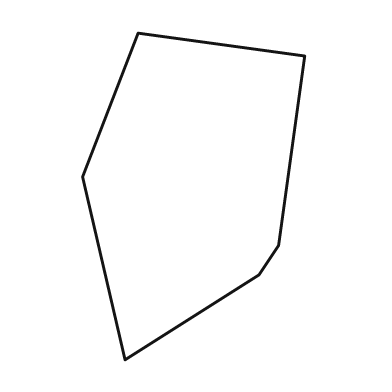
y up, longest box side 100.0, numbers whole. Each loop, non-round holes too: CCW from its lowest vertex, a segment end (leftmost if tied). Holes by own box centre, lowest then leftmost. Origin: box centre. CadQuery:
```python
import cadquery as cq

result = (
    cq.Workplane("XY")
    .moveTo(-21.0, -50.0)
    .lineTo(20.0, -24.0)
    .lineTo(26.0, -15.0)
    .lineTo(34.0, 43.0)
    .lineTo(-17.0, 50.0)
    .lineTo(-34.0, 6.0)
    .close()
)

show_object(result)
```